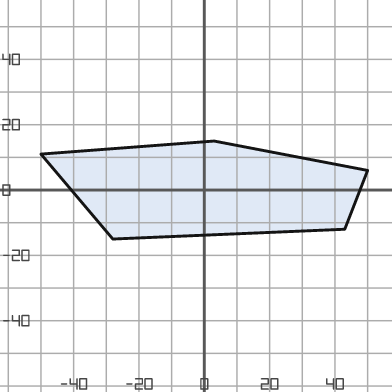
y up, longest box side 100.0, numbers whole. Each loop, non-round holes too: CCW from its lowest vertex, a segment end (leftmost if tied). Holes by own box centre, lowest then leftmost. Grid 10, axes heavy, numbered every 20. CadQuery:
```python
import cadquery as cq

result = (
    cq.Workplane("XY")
    .moveTo(-28.0, -15.0)
    .lineTo(43.0, -12.0)
    .lineTo(50.0, 6.0)
    .lineTo(3.0, 15.0)
    .lineTo(-50.0, 11.0)
    .close()
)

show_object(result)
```